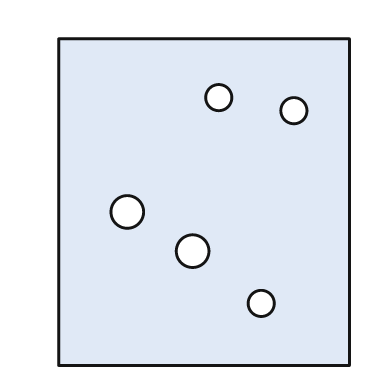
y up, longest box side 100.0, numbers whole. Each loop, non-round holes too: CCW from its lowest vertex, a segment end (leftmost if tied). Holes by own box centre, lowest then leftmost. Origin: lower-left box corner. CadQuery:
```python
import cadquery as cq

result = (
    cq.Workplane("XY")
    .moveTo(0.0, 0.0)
    .lineTo(89.0, 0.0)
    .lineTo(89.0, 100.0)
    .lineTo(0.0, 100.0)
    .close()
    .moveTo(62.0, 19.0)
    .circle(4.0)
    .moveTo(41.0, 35.0)
    .circle(5.0)
    .moveTo(21.0, 47.0)
    .circle(5.0)
    .moveTo(72.0, 78.0)
    .circle(4.0)
    .moveTo(49.0, 82.0)
    .circle(4.0)
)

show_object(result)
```